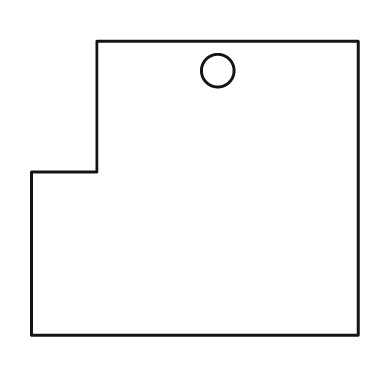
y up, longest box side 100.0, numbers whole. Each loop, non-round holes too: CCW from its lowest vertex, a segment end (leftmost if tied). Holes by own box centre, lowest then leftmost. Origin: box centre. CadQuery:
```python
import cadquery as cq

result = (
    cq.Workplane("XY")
    .moveTo(-50.0, -45.0)
    .lineTo(50.0, -45.0)
    .lineTo(50.0, 45.0)
    .lineTo(-30.0, 45.0)
    .lineTo(-30.0, 5.0)
    .lineTo(-50.0, 5.0)
    .close()
    .moveTo(7.0, 36.0)
    .circle(5.0)
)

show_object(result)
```